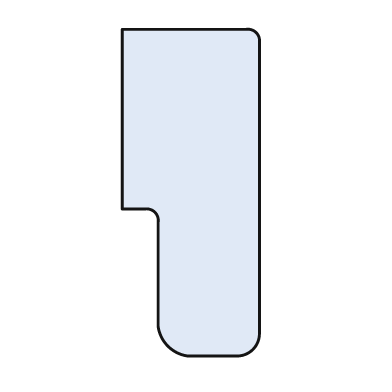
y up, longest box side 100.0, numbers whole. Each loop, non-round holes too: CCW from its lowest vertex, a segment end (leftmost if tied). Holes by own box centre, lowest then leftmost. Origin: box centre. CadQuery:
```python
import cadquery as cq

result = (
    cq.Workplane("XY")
    .moveTo(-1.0, -50.0)
    .lineTo(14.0, -50.0)
    .threePointArc((19.0, -48.0), (21.0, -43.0))
    .lineTo(21.0, 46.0)
    .threePointArc((20.0, 49.0), (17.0, 50.0))
    .lineTo(-21.0, 50.0)
    .lineTo(-21.0, -5.0)
    .lineTo(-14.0, -5.0)
    .threePointArc((-11.0, -6.0), (-10.0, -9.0))
    .lineTo(-10.0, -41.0)
    .threePointArc((-7.0, -47.0), (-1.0, -50.0))
    .close()
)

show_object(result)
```